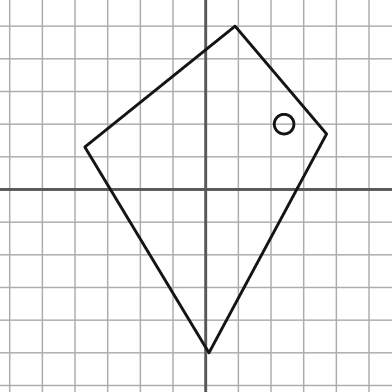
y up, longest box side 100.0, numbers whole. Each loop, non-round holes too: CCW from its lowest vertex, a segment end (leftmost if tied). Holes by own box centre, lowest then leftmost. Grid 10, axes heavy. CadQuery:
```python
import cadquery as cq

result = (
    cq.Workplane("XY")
    .moveTo(1.0, -50.0)
    .lineTo(37.0, 17.0)
    .lineTo(9.0, 50.0)
    .lineTo(-37.0, 13.0)
    .close()
    .moveTo(24.0, 20.0)
    .circle(3.0)
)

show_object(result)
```